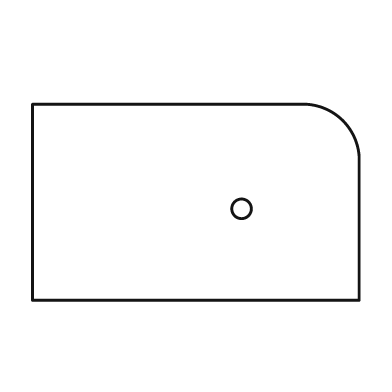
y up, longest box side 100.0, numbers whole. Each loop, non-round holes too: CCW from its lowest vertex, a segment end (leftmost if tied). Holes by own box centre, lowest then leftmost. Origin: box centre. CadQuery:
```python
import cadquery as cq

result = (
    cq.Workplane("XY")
    .moveTo(-50.0, -30.0)
    .lineTo(50.0, -30.0)
    .lineTo(50.0, 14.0)
    .threePointArc((45.0, 25.0), (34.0, 30.0))
    .lineTo(-50.0, 30.0)
    .close()
    .moveTo(14.0, -2.0)
    .circle(3.0)
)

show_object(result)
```